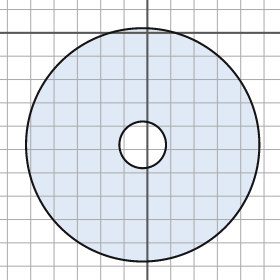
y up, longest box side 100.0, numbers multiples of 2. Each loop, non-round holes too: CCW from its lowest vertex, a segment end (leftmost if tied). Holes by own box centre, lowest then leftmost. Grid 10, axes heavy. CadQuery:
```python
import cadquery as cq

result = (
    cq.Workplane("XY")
    .moveTo(-2.0, -48.0)
    .circle(50.0)
    .moveTo(-2.0, -48.0)
    .circle(10.0)
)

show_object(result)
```